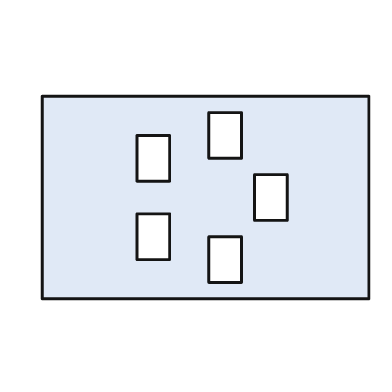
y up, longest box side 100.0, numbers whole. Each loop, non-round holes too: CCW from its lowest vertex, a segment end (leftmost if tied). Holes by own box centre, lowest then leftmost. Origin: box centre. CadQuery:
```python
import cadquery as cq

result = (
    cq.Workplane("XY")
    .moveTo(-50.0, -31.0)
    .lineTo(50.0, -31.0)
    .lineTo(50.0, 31.0)
    .lineTo(-50.0, 31.0)
    .close()
    .moveTo(1.0, -26.0)
    .lineTo(11.0, -26.0)
    .lineTo(11.0, -12.0)
    .lineTo(1.0, -12.0)
    .close()
    .moveTo(-21.0, -19.0)
    .lineTo(-11.0, -19.0)
    .lineTo(-11.0, -5.0)
    .lineTo(-21.0, -5.0)
    .close()
    .moveTo(15.0, -7.0)
    .lineTo(25.0, -7.0)
    .lineTo(25.0, 7.0)
    .lineTo(15.0, 7.0)
    .close()
    .moveTo(-21.0, 5.0)
    .lineTo(-11.0, 5.0)
    .lineTo(-11.0, 19.0)
    .lineTo(-21.0, 19.0)
    .close()
    .moveTo(1.0, 12.0)
    .lineTo(11.0, 12.0)
    .lineTo(11.0, 26.0)
    .lineTo(1.0, 26.0)
    .close()
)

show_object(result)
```